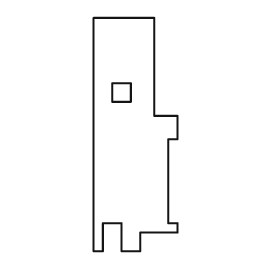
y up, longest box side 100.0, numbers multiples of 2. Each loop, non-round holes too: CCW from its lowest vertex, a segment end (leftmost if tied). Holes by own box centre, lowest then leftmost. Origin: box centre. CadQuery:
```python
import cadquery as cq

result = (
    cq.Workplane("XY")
    .moveTo(-18.0, -50.0)
    .lineTo(-14.0, -50.0)
    .lineTo(-14.0, -38.0)
    .lineTo(-6.0, -38.0)
    .lineTo(-6.0, -50.0)
    .lineTo(2.0, -50.0)
    .lineTo(2.0, -42.0)
    .lineTo(18.0, -42.0)
    .lineTo(18.0, -38.0)
    .lineTo(14.0, -38.0)
    .lineTo(14.0, -2.0)
    .lineTo(18.0, -2.0)
    .lineTo(18.0, 8.0)
    .lineTo(8.0, 8.0)
    .lineTo(8.0, 50.0)
    .lineTo(-18.0, 50.0)
    .close()
    .moveTo(-10.0, 14.0)
    .lineTo(-2.0, 14.0)
    .lineTo(-2.0, 22.0)
    .lineTo(-10.0, 22.0)
    .close()
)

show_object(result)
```